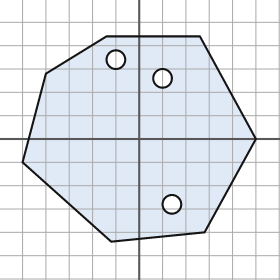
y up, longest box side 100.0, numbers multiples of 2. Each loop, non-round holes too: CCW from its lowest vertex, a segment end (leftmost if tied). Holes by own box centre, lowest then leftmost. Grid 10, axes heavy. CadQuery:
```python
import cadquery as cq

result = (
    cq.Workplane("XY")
    .moveTo(-12.0, -44.0)
    .lineTo(28.0, -40.0)
    .lineTo(50.0, 0.0)
    .lineTo(26.0, 44.0)
    .lineTo(-14.0, 44.0)
    .lineTo(-40.0, 28.0)
    .lineTo(-50.0, -10.0)
    .close()
    .moveTo(14.0, -28.0)
    .circle(4.0)
    .moveTo(10.0, 26.0)
    .circle(4.0)
    .moveTo(-10.0, 34.0)
    .circle(4.0)
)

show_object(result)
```